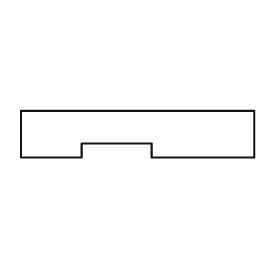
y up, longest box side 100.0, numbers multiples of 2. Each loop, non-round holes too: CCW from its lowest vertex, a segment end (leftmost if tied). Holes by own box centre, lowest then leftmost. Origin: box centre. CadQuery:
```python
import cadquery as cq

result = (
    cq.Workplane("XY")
    .moveTo(-50.0, -10.0)
    .lineTo(-24.0, -10.0)
    .lineTo(-24.0, -4.0)
    .lineTo(6.0, -4.0)
    .lineTo(6.0, -10.0)
    .lineTo(50.0, -10.0)
    .lineTo(50.0, 10.0)
    .lineTo(-50.0, 10.0)
    .close()
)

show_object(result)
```